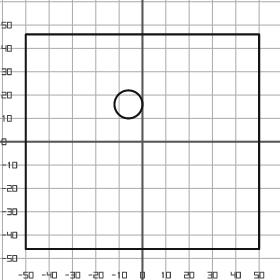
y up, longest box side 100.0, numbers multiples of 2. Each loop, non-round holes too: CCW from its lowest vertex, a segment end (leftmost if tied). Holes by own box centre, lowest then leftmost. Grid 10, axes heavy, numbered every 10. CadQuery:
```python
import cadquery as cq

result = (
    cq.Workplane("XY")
    .moveTo(-50.0, -46.0)
    .lineTo(50.0, -46.0)
    .lineTo(50.0, 46.0)
    .lineTo(-50.0, 46.0)
    .close()
    .moveTo(-6.0, 16.0)
    .circle(6.0)
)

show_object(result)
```